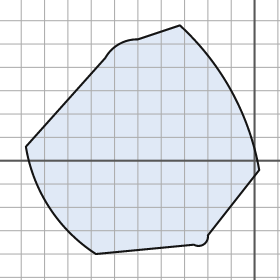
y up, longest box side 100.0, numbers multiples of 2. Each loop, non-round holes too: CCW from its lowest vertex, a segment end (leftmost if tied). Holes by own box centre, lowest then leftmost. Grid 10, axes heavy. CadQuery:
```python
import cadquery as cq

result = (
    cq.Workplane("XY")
    .moveTo(-68.0, -40.0)
    .lineTo(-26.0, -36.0)
    .threePointArc((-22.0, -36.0), (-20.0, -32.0))
    .lineTo(2.0, -4.0)
    .threePointArc((-10.0, 30.0), (-32.0, 58.0))
    .lineTo(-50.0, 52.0)
    .threePointArc((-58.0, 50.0), (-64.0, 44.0))
    .lineTo(-98.0, 6.0)
    .threePointArc((-88.0, -20.0), (-68.0, -40.0))
    .close()
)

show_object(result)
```